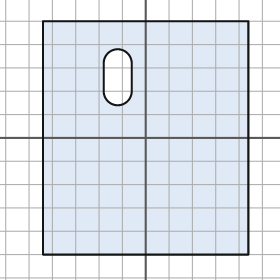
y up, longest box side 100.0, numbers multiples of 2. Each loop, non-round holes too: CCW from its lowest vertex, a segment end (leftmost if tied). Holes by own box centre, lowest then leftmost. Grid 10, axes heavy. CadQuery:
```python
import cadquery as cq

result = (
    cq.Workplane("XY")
    .moveTo(-44.0, -50.0)
    .lineTo(44.0, -50.0)
    .lineTo(44.0, 50.0)
    .lineTo(-44.0, 50.0)
    .close()
    .moveTo(-18.0, 20.0)
    .threePointArc((-12.0, 14.0), (-6.0, 20.0))
    .lineTo(-6.0, 32.0)
    .threePointArc((-12.0, 38.0), (-18.0, 32.0))
    .close()
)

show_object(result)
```